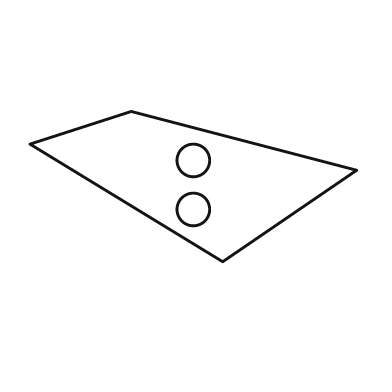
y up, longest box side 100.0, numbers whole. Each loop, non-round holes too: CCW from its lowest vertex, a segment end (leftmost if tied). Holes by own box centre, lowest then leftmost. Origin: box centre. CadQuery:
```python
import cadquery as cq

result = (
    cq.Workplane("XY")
    .moveTo(9.0, -23.0)
    .lineTo(50.0, 5.0)
    .lineTo(-19.0, 23.0)
    .lineTo(-50.0, 13.0)
    .close()
    .moveTo(0.0, -7.0)
    .circle(5.0)
    .moveTo(0.0, 8.0)
    .circle(5.0)
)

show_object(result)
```